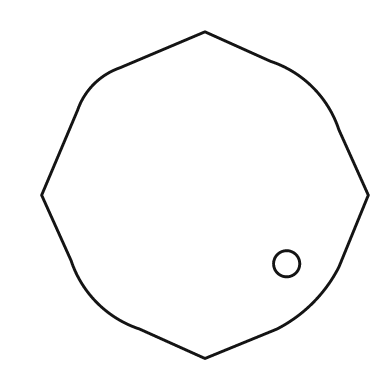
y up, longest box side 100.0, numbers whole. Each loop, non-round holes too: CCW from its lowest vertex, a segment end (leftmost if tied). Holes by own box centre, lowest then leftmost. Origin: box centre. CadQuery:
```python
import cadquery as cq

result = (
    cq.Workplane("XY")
    .moveTo(0.0, -50.0)
    .lineTo(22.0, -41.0)
    .threePointArc((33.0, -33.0), (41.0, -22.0))
    .lineTo(50.0, 0.0)
    .lineTo(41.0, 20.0)
    .threePointArc((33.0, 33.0), (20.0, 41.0))
    .lineTo(0.0, 50.0)
    .lineTo(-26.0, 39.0)
    .threePointArc((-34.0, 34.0), (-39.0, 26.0))
    .lineTo(-50.0, 0.0)
    .lineTo(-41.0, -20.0)
    .threePointArc((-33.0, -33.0), (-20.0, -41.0))
    .close()
    .moveTo(25.0, -21.0)
    .circle(4.0)
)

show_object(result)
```